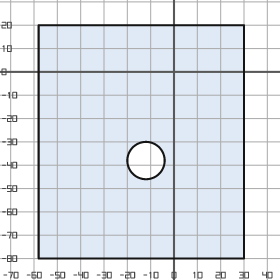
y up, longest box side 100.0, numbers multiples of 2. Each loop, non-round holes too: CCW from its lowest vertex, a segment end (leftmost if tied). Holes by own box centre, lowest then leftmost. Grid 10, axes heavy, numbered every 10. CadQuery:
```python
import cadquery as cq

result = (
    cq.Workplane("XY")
    .moveTo(-58.0, -80.0)
    .lineTo(30.0, -80.0)
    .lineTo(30.0, 20.0)
    .lineTo(-58.0, 20.0)
    .close()
    .moveTo(-12.0, -38.0)
    .circle(8.0)
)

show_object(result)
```